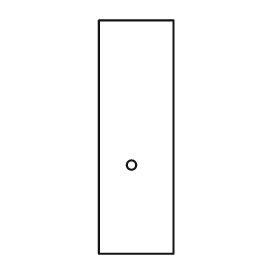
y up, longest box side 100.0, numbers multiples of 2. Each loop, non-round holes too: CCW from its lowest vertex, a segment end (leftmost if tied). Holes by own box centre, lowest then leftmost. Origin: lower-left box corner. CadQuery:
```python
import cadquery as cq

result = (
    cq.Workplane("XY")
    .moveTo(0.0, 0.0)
    .lineTo(32.0, 0.0)
    .lineTo(32.0, 100.0)
    .lineTo(0.0, 100.0)
    .close()
    .moveTo(14.0, 38.0)
    .circle(2.0)
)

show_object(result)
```